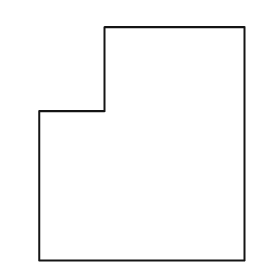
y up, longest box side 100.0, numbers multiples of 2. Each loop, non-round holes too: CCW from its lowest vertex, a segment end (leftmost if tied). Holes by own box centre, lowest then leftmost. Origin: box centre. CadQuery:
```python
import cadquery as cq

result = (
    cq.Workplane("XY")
    .moveTo(-44.0, -50.0)
    .lineTo(44.0, -50.0)
    .lineTo(44.0, 50.0)
    .lineTo(-16.0, 50.0)
    .lineTo(-16.0, 14.0)
    .lineTo(-44.0, 14.0)
    .close()
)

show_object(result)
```